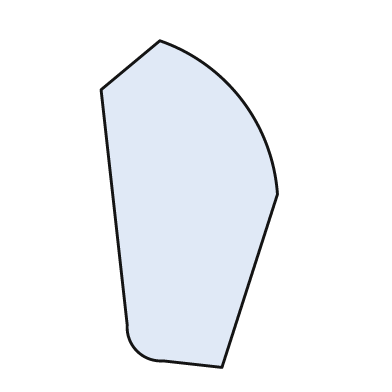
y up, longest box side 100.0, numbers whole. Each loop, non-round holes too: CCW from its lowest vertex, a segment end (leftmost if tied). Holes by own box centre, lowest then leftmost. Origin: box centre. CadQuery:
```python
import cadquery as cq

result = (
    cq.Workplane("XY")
    .moveTo(10.0, -50.0)
    .lineTo(27.0, 3.0)
    .threePointArc((16.0, 32.0), (-9.0, 50.0))
    .lineTo(-27.0, 35.0)
    .lineTo(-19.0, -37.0)
    .threePointArc((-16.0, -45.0), (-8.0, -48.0))
    .close()
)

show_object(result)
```